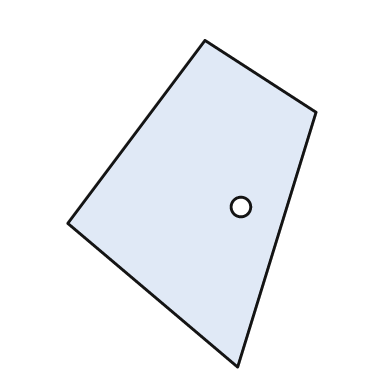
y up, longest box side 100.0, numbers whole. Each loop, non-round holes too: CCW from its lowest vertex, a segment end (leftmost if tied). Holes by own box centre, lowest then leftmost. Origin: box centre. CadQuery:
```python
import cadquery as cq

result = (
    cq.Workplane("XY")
    .moveTo(14.0, -50.0)
    .lineTo(38.0, 28.0)
    .lineTo(4.0, 50.0)
    .lineTo(-38.0, -6.0)
    .close()
    .moveTo(15.0, -1.0)
    .circle(3.0)
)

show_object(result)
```